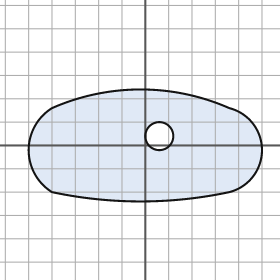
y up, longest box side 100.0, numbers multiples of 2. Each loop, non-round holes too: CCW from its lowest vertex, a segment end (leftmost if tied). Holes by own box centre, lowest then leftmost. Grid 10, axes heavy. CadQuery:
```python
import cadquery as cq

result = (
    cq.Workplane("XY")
    .moveTo(-40.0, -20.0)
    .threePointArc((-2.0, -24.0), (36.0, -20.0))
    .threePointArc((50.0, -2.0), (36.0, 16.0))
    .threePointArc((-2.0, 24.0), (-40.0, 16.0))
    .threePointArc((-50.0, -2.0), (-40.0, -20.0))
    .close()
    .moveTo(6.0, 4.0)
    .circle(6.0)
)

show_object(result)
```